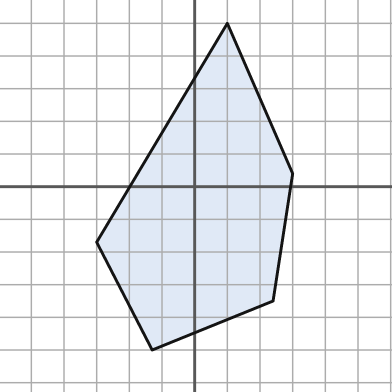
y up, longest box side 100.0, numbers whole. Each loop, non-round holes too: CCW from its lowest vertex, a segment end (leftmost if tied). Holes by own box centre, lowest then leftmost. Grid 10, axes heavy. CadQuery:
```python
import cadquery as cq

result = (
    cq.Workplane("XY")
    .moveTo(-13.0, -50.0)
    .lineTo(24.0, -35.0)
    .lineTo(30.0, 4.0)
    .lineTo(10.0, 50.0)
    .lineTo(-30.0, -17.0)
    .close()
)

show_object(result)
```